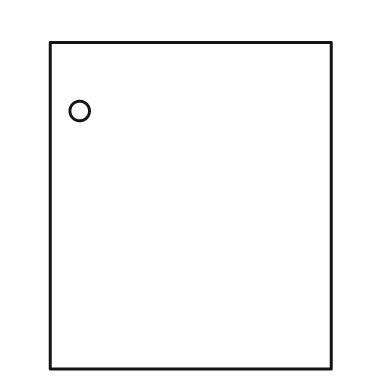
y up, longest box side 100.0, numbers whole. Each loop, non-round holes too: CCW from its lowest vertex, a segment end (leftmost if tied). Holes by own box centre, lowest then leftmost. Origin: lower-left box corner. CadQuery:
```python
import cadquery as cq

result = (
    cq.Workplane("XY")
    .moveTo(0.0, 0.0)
    .lineTo(86.0, 0.0)
    .lineTo(86.0, 100.0)
    .lineTo(0.0, 100.0)
    .close()
    .moveTo(9.0, 79.0)
    .circle(3.0)
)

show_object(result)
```